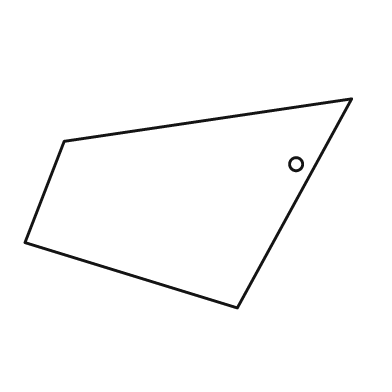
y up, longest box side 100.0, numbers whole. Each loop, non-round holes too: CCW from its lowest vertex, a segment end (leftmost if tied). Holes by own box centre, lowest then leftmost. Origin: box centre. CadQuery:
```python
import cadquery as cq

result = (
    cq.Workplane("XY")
    .moveTo(15.0, -32.0)
    .lineTo(50.0, 32.0)
    .lineTo(-38.0, 19.0)
    .lineTo(-50.0, -12.0)
    .close()
    .moveTo(33.0, 12.0)
    .circle(2.0)
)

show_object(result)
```